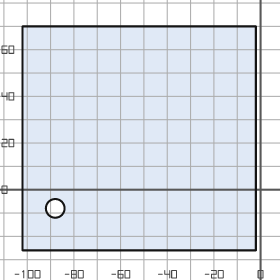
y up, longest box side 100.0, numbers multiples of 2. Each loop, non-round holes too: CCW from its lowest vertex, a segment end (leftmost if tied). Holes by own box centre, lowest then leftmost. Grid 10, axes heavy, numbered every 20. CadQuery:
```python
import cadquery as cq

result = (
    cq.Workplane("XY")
    .moveTo(-102.0, -26.0)
    .lineTo(-2.0, -26.0)
    .lineTo(-2.0, 70.0)
    .lineTo(-102.0, 70.0)
    .close()
    .moveTo(-88.0, -8.0)
    .circle(4.0)
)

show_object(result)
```